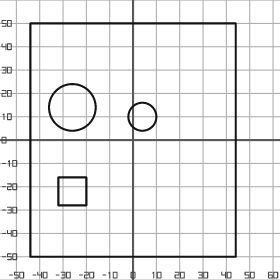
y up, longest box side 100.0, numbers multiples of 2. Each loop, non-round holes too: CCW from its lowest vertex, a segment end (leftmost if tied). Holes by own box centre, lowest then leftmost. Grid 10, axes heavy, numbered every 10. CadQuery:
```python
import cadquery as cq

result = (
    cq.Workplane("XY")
    .moveTo(-44.0, -50.0)
    .lineTo(44.0, -50.0)
    .lineTo(44.0, 50.0)
    .lineTo(-44.0, 50.0)
    .close()
    .moveTo(-32.0, -28.0)
    .lineTo(-20.0, -28.0)
    .lineTo(-20.0, -16.0)
    .lineTo(-32.0, -16.0)
    .close()
    .moveTo(4.0, 10.0)
    .circle(6.0)
    .moveTo(-26.0, 14.0)
    .circle(10.0)
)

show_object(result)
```